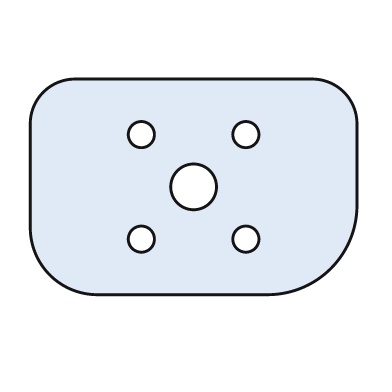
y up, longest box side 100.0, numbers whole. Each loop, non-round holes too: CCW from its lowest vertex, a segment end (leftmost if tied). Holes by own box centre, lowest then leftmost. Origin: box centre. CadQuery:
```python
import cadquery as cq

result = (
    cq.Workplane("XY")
    .moveTo(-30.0, -33.0)
    .lineTo(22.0, -33.0)
    .threePointArc((42.0, -25.0), (50.0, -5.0))
    .lineTo(50.0, 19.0)
    .threePointArc((46.0, 29.0), (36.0, 33.0))
    .lineTo(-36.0, 33.0)
    .threePointArc((-46.0, 29.0), (-50.0, 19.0))
    .lineTo(-50.0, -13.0)
    .threePointArc((-44.0, -27.0), (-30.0, -33.0))
    .close()
    .moveTo(-16.0, -16.0)
    .circle(4.0)
    .moveTo(16.0, -16.0)
    .circle(4.0)
    .moveTo(0.0, 0.0)
    .circle(7.0)
    .moveTo(-16.0, 16.0)
    .circle(4.0)
    .moveTo(16.0, 16.0)
    .circle(4.0)
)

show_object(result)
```